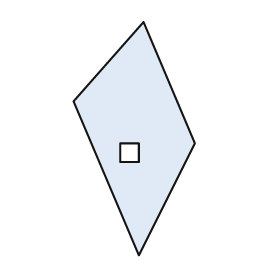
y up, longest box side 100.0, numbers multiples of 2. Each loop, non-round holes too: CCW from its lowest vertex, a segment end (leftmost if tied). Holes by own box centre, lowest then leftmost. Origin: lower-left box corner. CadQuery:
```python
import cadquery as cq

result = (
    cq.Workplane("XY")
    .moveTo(28.0, 0.0)
    .lineTo(52.0, 48.0)
    .lineTo(30.0, 100.0)
    .lineTo(0.0, 66.0)
    .close()
    .moveTo(20.0, 40.0)
    .lineTo(28.0, 40.0)
    .lineTo(28.0, 48.0)
    .lineTo(20.0, 48.0)
    .close()
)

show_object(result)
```